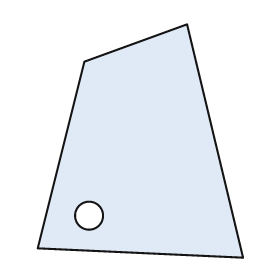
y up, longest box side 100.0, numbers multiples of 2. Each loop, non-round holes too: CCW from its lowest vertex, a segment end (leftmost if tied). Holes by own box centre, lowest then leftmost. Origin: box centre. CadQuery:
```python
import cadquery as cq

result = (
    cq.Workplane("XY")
    .moveTo(44.0, -50.0)
    .lineTo(20.0, 50.0)
    .lineTo(-24.0, 34.0)
    .lineTo(-44.0, -46.0)
    .close()
    .moveTo(-22.0, -32.0)
    .circle(6.0)
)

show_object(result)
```